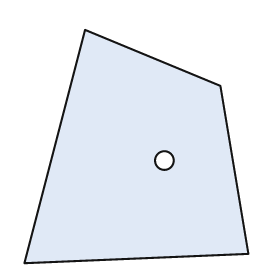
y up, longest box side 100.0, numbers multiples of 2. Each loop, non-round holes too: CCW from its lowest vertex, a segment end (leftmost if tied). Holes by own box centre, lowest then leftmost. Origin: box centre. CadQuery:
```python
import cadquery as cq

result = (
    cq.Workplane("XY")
    .moveTo(-48.0, -50.0)
    .lineTo(48.0, -46.0)
    .lineTo(36.0, 26.0)
    .lineTo(-22.0, 50.0)
    .close()
    .moveTo(12.0, -6.0)
    .circle(4.0)
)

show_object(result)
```